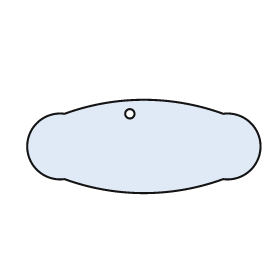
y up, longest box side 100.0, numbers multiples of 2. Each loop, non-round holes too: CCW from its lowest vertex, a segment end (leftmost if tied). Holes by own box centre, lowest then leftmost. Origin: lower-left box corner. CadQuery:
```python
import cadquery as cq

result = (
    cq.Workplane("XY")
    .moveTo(16.0, 6.0)
    .threePointArc((50.0, 0.0), (84.0, 6.0))
    .threePointArc((100.0, 20.0), (84.0, 34.0))
    .threePointArc((50.0, 40.0), (16.0, 34.0))
    .threePointArc((0.0, 20.0), (16.0, 6.0))
    .close()
    .moveTo(44.0, 34.0)
    .circle(2.0)
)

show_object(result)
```